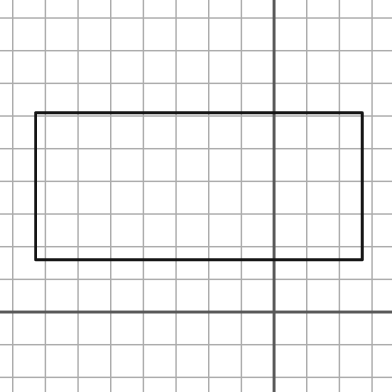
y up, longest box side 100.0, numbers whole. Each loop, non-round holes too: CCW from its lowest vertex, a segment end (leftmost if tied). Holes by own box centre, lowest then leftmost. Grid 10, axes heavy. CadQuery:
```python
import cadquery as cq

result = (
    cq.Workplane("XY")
    .moveTo(-73.0, 16.0)
    .lineTo(27.0, 16.0)
    .lineTo(27.0, 61.0)
    .lineTo(-73.0, 61.0)
    .close()
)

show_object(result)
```